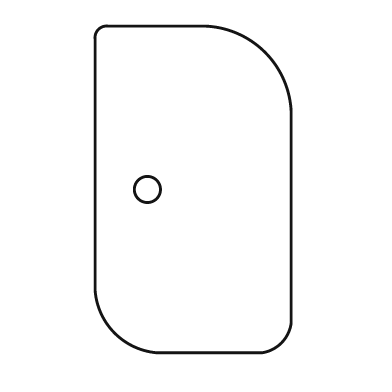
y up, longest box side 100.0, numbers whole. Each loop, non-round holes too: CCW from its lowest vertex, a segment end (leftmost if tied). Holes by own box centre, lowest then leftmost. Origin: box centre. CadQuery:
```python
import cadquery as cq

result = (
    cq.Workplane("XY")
    .moveTo(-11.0, -50.0)
    .lineTo(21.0, -50.0)
    .threePointArc((27.0, -47.0), (30.0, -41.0))
    .lineTo(30.0, 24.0)
    .threePointArc((22.0, 42.0), (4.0, 50.0))
    .lineTo(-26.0, 50.0)
    .threePointArc((-29.0, 49.0), (-30.0, 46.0))
    .lineTo(-30.0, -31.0)
    .threePointArc((-24.0, -44.0), (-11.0, -50.0))
    .close()
    .moveTo(-14.0, 0.0)
    .circle(4.0)
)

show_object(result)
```